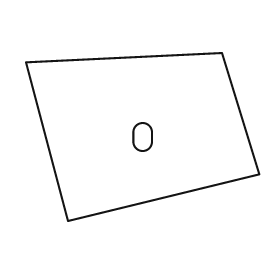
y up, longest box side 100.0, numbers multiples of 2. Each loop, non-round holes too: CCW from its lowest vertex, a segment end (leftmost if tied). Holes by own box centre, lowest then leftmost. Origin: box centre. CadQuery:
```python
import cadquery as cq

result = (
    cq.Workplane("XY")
    .moveTo(-32.0, -36.0)
    .lineTo(50.0, -16.0)
    .lineTo(34.0, 36.0)
    .lineTo(-50.0, 32.0)
    .close()
    .moveTo(-4.0, -2.0)
    .threePointArc((0.0, -6.0), (4.0, -2.0))
    .lineTo(4.0, 2.0)
    .threePointArc((0.0, 6.0), (-4.0, 2.0))
    .close()
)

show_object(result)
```